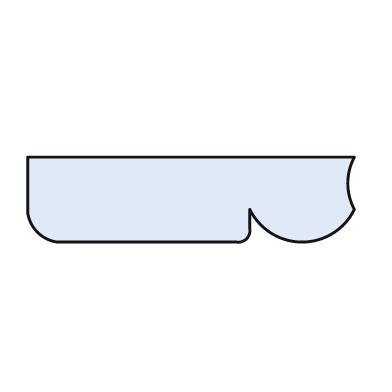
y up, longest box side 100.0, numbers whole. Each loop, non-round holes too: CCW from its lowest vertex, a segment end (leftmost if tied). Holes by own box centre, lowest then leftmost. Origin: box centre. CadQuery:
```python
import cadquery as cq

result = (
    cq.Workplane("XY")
    .moveTo(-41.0, -13.0)
    .lineTo(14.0, -13.0)
    .threePointArc((17.0, -12.0), (18.0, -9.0))
    .lineTo(18.0, -3.0)
    .threePointArc((34.0, -13.0), (50.0, -3.0))
    .threePointArc((48.0, 5.0), (50.0, 13.0))
    .lineTo(-50.0, 13.0)
    .lineTo(-50.0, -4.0)
    .threePointArc((-47.0, -10.0), (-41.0, -13.0))
    .close()
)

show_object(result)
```